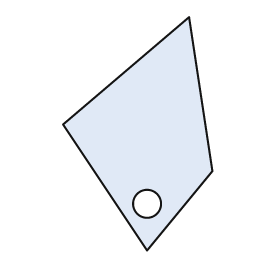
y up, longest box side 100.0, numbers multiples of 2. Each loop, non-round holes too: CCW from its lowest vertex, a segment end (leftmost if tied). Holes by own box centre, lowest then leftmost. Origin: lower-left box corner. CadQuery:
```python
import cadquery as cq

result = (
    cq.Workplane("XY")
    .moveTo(36.0, 0.0)
    .lineTo(64.0, 34.0)
    .lineTo(54.0, 100.0)
    .lineTo(0.0, 54.0)
    .close()
    .moveTo(36.0, 20.0)
    .circle(6.0)
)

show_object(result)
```